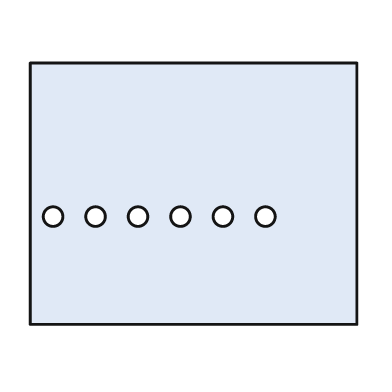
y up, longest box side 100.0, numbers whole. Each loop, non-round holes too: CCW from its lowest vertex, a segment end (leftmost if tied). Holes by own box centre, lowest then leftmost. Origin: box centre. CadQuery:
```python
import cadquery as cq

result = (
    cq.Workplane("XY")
    .moveTo(-50.0, -40.0)
    .lineTo(50.0, -40.0)
    .lineTo(50.0, 40.0)
    .lineTo(-50.0, 40.0)
    .close()
    .moveTo(-43.0, -7.0)
    .circle(3.0)
    .moveTo(-30.0, -7.0)
    .circle(3.0)
    .moveTo(-17.0, -7.0)
    .circle(3.0)
    .moveTo(-4.0, -7.0)
    .circle(3.0)
    .moveTo(9.0, -7.0)
    .circle(3.0)
    .moveTo(22.0, -7.0)
    .circle(3.0)
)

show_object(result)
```